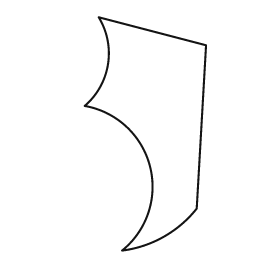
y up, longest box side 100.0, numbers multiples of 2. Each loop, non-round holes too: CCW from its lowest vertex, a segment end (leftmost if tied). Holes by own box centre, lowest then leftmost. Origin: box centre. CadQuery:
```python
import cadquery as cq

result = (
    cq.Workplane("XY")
    .moveTo(-10.0, -50.0)
    .threePointArc((8.0, -44.0), (22.0, -32.0))
    .lineTo(26.0, 38.0)
    .lineTo(-20.0, 50.0)
    .threePointArc((-16.0, 30.0), (-26.0, 12.0))
    .threePointArc((2.0, -14.0), (-10.0, -50.0))
    .close()
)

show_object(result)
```